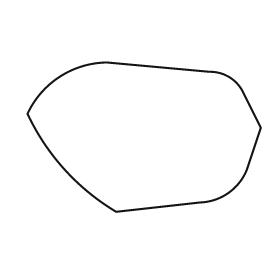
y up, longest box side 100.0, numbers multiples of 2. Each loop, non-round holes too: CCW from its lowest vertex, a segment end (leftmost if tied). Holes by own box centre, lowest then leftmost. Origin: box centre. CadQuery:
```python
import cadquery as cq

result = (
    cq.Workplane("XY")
    .moveTo(-12.0, -32.0)
    .lineTo(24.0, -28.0)
    .threePointArc((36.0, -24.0), (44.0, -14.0))
    .lineTo(50.0, 4.0)
    .lineTo(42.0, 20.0)
    .threePointArc((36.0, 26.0), (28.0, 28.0))
    .lineTo(-16.0, 32.0)
    .threePointArc((-36.0, 26.0), (-50.0, 10.0))
    .threePointArc((-34.0, -14.0), (-12.0, -32.0))
    .close()
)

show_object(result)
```